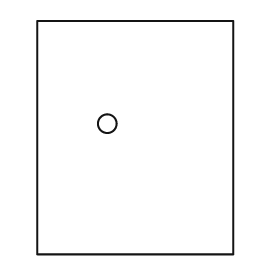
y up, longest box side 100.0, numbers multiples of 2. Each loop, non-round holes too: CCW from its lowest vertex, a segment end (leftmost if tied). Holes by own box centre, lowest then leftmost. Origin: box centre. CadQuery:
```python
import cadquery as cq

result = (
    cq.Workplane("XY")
    .moveTo(-42.0, -50.0)
    .lineTo(42.0, -50.0)
    .lineTo(42.0, 50.0)
    .lineTo(-42.0, 50.0)
    .close()
    .moveTo(-12.0, 6.0)
    .circle(4.0)
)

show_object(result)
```